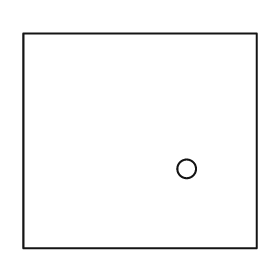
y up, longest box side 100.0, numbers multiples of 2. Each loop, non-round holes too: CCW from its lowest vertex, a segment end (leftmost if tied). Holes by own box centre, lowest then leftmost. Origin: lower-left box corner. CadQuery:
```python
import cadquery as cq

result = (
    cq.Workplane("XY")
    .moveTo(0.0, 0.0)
    .lineTo(100.0, 0.0)
    .lineTo(100.0, 92.0)
    .lineTo(0.0, 92.0)
    .close()
    .moveTo(70.0, 34.0)
    .circle(4.0)
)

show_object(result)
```